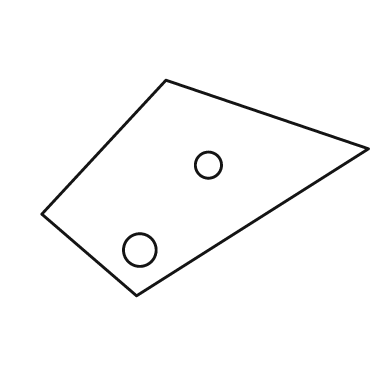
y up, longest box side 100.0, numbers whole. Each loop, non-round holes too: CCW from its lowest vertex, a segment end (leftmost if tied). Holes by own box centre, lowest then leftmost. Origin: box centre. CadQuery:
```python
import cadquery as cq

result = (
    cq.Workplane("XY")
    .moveTo(-21.0, -33.0)
    .lineTo(50.0, 12.0)
    .lineTo(-12.0, 33.0)
    .lineTo(-50.0, -8.0)
    .close()
    .moveTo(-20.0, -19.0)
    .circle(5.0)
    .moveTo(1.0, 7.0)
    .circle(4.0)
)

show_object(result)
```